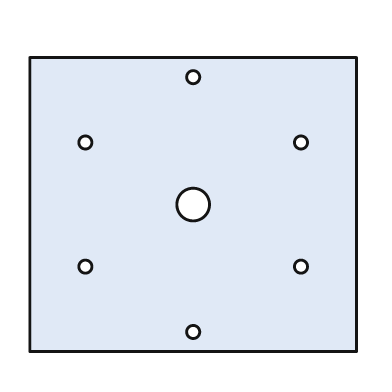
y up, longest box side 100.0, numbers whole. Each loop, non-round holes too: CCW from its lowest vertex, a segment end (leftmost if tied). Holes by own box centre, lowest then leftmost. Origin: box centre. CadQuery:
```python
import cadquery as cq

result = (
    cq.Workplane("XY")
    .moveTo(-50.0, -45.0)
    .lineTo(50.0, -45.0)
    .lineTo(50.0, 45.0)
    .lineTo(-50.0, 45.0)
    .close()
    .moveTo(0.0, -39.0)
    .circle(2.0)
    .moveTo(-33.0, -19.0)
    .circle(2.0)
    .moveTo(33.0, -19.0)
    .circle(2.0)
    .moveTo(0.0, 0.0)
    .circle(5.0)
    .moveTo(-33.0, 19.0)
    .circle(2.0)
    .moveTo(33.0, 19.0)
    .circle(2.0)
    .moveTo(0.0, 39.0)
    .circle(2.0)
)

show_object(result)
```